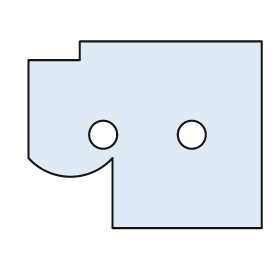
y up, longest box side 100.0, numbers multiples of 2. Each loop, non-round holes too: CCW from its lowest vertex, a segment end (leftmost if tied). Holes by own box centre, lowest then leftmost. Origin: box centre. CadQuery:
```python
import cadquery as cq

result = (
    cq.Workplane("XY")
    .moveTo(-14.0, -40.0)
    .lineTo(50.0, -40.0)
    .lineTo(50.0, 40.0)
    .lineTo(-28.0, 40.0)
    .lineTo(-28.0, 32.0)
    .lineTo(-50.0, 32.0)
    .lineTo(-50.0, -10.0)
    .threePointArc((-32.0, -18.0), (-14.0, -10.0))
    .close()
    .moveTo(-18.0, 0.0)
    .circle(6.0)
    .moveTo(20.0, 0.0)
    .circle(6.0)
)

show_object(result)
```